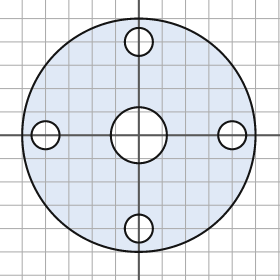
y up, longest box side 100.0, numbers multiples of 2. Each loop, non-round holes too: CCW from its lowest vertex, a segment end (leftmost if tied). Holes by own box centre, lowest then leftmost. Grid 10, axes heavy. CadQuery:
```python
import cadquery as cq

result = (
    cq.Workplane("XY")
    .moveTo(0.0, 0.0)
    .circle(50.0)
    .moveTo(0.0, -40.0)
    .circle(6.0)
    .moveTo(-40.0, 0.0)
    .circle(6.0)
    .moveTo(0.0, 0.0)
    .circle(12.0)
    .moveTo(40.0, 0.0)
    .circle(6.0)
    .moveTo(0.0, 40.0)
    .circle(6.0)
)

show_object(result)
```